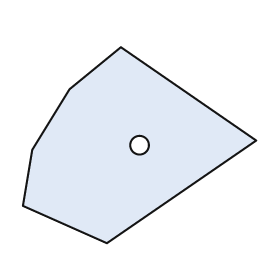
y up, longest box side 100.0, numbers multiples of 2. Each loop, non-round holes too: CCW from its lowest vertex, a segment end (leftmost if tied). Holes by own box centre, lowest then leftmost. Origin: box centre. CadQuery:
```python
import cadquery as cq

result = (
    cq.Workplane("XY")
    .moveTo(-14.0, -42.0)
    .lineTo(50.0, 2.0)
    .lineTo(-8.0, 42.0)
    .lineTo(-30.0, 24.0)
    .lineTo(-46.0, -2.0)
    .lineTo(-50.0, -26.0)
    .close()
    .moveTo(0.0, 0.0)
    .circle(4.0)
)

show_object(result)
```